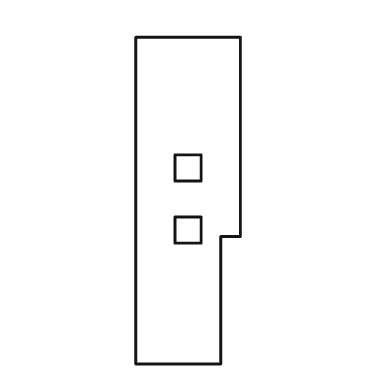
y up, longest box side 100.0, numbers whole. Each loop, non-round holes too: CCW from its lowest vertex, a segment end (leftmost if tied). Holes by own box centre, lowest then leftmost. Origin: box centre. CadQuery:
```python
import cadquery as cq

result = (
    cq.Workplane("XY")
    .moveTo(-16.0, -50.0)
    .lineTo(10.0, -50.0)
    .lineTo(10.0, -11.0)
    .lineTo(16.0, -11.0)
    .lineTo(16.0, 50.0)
    .lineTo(-16.0, 50.0)
    .close()
    .moveTo(-4.0, -13.0)
    .lineTo(4.0, -13.0)
    .lineTo(4.0, -5.0)
    .lineTo(-4.0, -5.0)
    .close()
    .moveTo(-4.0, 6.0)
    .lineTo(4.0, 6.0)
    .lineTo(4.0, 14.0)
    .lineTo(-4.0, 14.0)
    .close()
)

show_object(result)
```